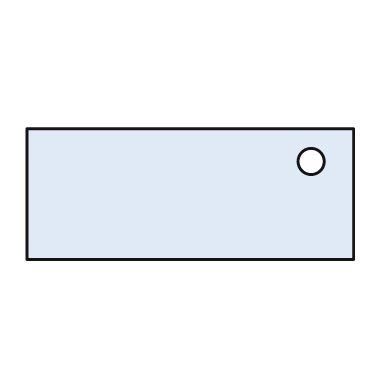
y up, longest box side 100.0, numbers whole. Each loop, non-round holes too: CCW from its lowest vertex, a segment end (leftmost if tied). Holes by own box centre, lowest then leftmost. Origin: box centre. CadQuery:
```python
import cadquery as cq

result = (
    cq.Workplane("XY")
    .moveTo(-50.0, -20.0)
    .lineTo(50.0, -20.0)
    .lineTo(50.0, 20.0)
    .lineTo(-50.0, 20.0)
    .close()
    .moveTo(37.0, 10.0)
    .circle(4.0)
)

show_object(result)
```